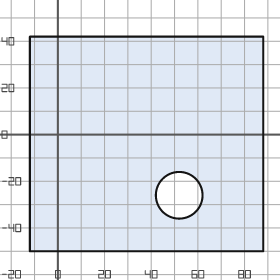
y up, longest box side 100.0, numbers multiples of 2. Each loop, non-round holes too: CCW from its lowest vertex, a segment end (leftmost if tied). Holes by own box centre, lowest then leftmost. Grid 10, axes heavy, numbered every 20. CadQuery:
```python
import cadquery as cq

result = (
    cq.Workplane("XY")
    .moveTo(-12.0, -50.0)
    .lineTo(88.0, -50.0)
    .lineTo(88.0, 42.0)
    .lineTo(-12.0, 42.0)
    .close()
    .moveTo(52.0, -26.0)
    .circle(10.0)
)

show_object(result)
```